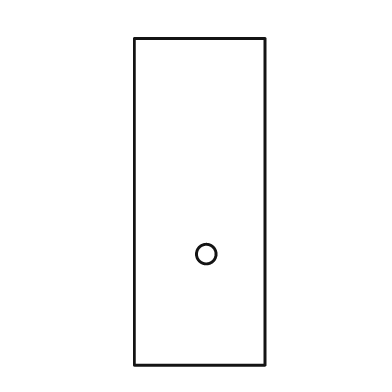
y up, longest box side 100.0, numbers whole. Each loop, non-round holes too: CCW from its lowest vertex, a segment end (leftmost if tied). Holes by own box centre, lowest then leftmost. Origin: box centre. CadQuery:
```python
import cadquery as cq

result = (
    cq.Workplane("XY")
    .moveTo(-20.0, -50.0)
    .lineTo(20.0, -50.0)
    .lineTo(20.0, 50.0)
    .lineTo(-20.0, 50.0)
    .close()
    .moveTo(2.0, -16.0)
    .circle(3.0)
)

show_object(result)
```